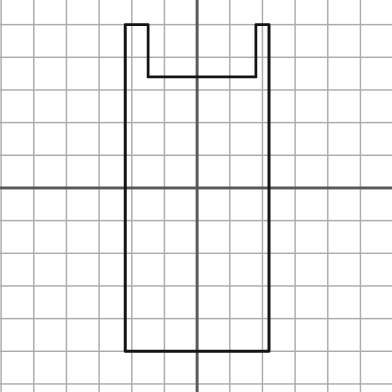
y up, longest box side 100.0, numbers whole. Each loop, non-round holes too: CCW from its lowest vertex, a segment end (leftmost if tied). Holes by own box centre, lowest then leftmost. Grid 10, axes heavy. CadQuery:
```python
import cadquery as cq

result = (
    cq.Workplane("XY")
    .moveTo(-22.0, -50.0)
    .lineTo(22.0, -50.0)
    .lineTo(22.0, 50.0)
    .lineTo(18.0, 50.0)
    .lineTo(18.0, 34.0)
    .lineTo(-15.0, 34.0)
    .lineTo(-15.0, 50.0)
    .lineTo(-22.0, 50.0)
    .close()
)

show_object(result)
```